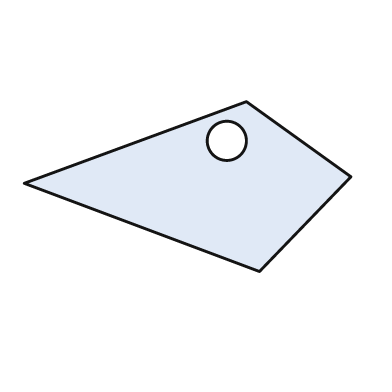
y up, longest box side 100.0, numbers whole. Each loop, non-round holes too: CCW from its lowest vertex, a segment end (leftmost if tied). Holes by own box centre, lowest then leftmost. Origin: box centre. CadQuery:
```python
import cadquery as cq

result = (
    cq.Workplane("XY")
    .moveTo(22.0, -26.0)
    .lineTo(50.0, 3.0)
    .lineTo(18.0, 26.0)
    .lineTo(-50.0, 1.0)
    .close()
    .moveTo(12.0, 14.0)
    .circle(6.0)
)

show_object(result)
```